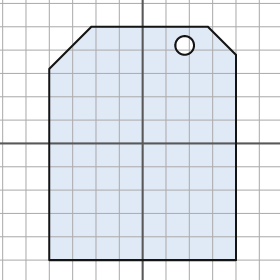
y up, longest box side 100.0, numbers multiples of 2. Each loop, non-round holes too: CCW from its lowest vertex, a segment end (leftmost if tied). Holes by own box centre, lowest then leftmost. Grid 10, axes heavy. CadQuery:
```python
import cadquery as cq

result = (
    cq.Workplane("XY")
    .moveTo(-40.0, -50.0)
    .lineTo(40.0, -50.0)
    .lineTo(40.0, 38.0)
    .lineTo(28.0, 50.0)
    .lineTo(-22.0, 50.0)
    .lineTo(-40.0, 32.0)
    .close()
    .moveTo(18.0, 42.0)
    .circle(4.0)
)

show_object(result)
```